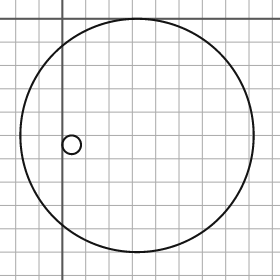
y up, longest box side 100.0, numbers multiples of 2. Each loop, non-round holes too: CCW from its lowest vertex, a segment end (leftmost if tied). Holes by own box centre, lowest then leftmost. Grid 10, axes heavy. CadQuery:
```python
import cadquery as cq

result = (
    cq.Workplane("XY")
    .moveTo(32.0, -50.0)
    .circle(50.0)
    .moveTo(4.0, -54.0)
    .circle(4.0)
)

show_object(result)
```